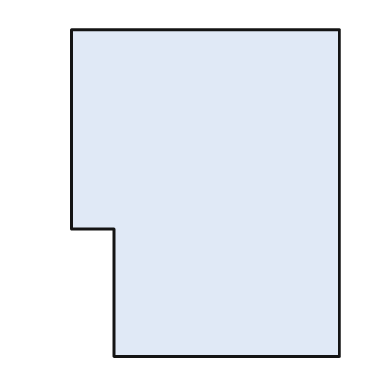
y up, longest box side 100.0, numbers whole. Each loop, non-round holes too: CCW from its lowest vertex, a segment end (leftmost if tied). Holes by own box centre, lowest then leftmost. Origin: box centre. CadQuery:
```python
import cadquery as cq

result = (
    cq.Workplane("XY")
    .moveTo(-28.0, -50.0)
    .lineTo(41.0, -50.0)
    .lineTo(41.0, 50.0)
    .lineTo(-41.0, 50.0)
    .lineTo(-41.0, -11.0)
    .lineTo(-28.0, -11.0)
    .close()
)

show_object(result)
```